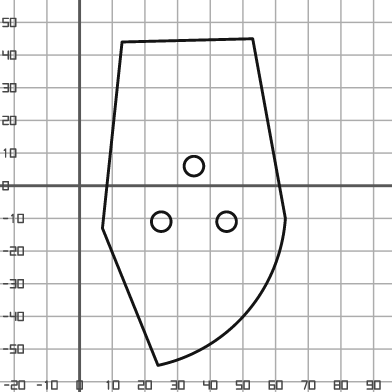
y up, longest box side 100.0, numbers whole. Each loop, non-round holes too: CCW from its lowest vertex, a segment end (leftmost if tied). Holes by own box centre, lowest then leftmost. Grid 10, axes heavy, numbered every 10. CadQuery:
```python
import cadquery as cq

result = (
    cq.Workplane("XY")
    .moveTo(24.0, -55.0)
    .threePointArc((51.0, -39.0), (63.0, -10.0))
    .lineTo(53.0, 45.0)
    .lineTo(13.0, 44.0)
    .lineTo(7.0, -13.0)
    .close()
    .moveTo(25.0, -11.0)
    .circle(3.0)
    .moveTo(45.0, -11.0)
    .circle(3.0)
    .moveTo(35.0, 6.0)
    .circle(3.0)
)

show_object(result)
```